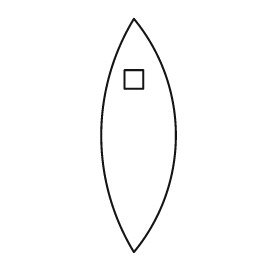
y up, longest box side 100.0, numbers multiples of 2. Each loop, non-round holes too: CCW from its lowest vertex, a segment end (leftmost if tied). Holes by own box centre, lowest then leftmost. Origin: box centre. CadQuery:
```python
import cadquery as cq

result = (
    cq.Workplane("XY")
    .moveTo(-2.0, -50.0)
    .threePointArc((16.0, 0.0), (-2.0, 50.0))
    .threePointArc((-16.0, 0.0), (-2.0, -50.0))
    .close()
    .moveTo(-6.0, 20.0)
    .lineTo(2.0, 20.0)
    .lineTo(2.0, 28.0)
    .lineTo(-6.0, 28.0)
    .close()
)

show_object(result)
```